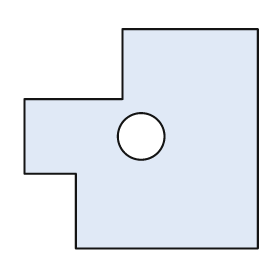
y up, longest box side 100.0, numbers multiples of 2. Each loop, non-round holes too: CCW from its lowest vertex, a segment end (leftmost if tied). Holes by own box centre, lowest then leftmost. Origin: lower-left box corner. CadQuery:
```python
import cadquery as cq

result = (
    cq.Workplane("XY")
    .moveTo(22.0, 0.0)
    .lineTo(100.0, 0.0)
    .lineTo(100.0, 94.0)
    .lineTo(42.0, 94.0)
    .lineTo(42.0, 64.0)
    .lineTo(0.0, 64.0)
    .lineTo(0.0, 32.0)
    .lineTo(22.0, 32.0)
    .close()
    .moveTo(50.0, 48.0)
    .circle(10.0)
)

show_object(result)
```